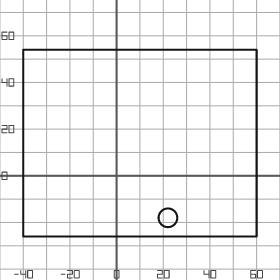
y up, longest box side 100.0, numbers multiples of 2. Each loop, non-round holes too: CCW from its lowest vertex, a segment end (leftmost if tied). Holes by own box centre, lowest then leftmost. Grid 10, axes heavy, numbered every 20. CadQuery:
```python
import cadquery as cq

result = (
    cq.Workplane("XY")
    .moveTo(-40.0, -26.0)
    .lineTo(60.0, -26.0)
    .lineTo(60.0, 54.0)
    .lineTo(-40.0, 54.0)
    .close()
    .moveTo(22.0, -18.0)
    .circle(4.0)
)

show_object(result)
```